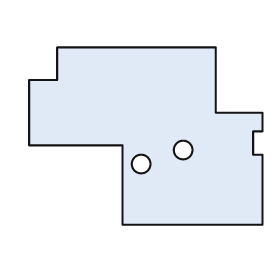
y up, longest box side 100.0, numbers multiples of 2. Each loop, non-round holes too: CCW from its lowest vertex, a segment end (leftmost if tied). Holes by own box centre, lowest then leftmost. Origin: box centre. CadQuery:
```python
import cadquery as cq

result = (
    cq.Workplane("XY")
    .moveTo(-10.0, -38.0)
    .lineTo(50.0, -38.0)
    .lineTo(50.0, -8.0)
    .lineTo(46.0, -8.0)
    .lineTo(46.0, 2.0)
    .lineTo(50.0, 2.0)
    .lineTo(50.0, 10.0)
    .lineTo(30.0, 10.0)
    .lineTo(30.0, 38.0)
    .lineTo(-38.0, 38.0)
    .lineTo(-38.0, 24.0)
    .lineTo(-50.0, 24.0)
    .lineTo(-50.0, -4.0)
    .lineTo(-10.0, -4.0)
    .close()
    .moveTo(-2.0, -12.0)
    .circle(4.0)
    .moveTo(16.0, -6.0)
    .circle(4.0)
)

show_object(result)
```